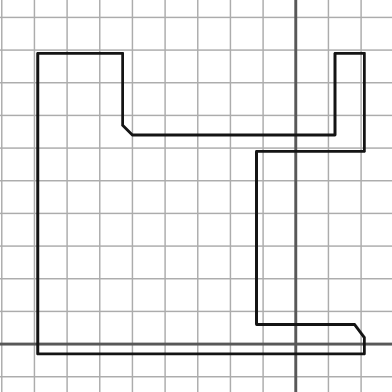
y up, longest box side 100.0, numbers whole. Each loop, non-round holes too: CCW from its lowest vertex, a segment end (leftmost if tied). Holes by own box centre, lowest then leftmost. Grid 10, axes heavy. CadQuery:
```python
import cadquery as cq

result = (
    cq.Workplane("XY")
    .moveTo(-79.0, -3.0)
    .lineTo(21.0, -3.0)
    .lineTo(21.0, 2.0)
    .lineTo(18.0, 6.0)
    .lineTo(-12.0, 6.0)
    .lineTo(-12.0, 59.0)
    .lineTo(21.0, 59.0)
    .lineTo(21.0, 89.0)
    .lineTo(12.0, 89.0)
    .lineTo(12.0, 64.0)
    .lineTo(-50.0, 64.0)
    .lineTo(-53.0, 67.0)
    .lineTo(-53.0, 89.0)
    .lineTo(-79.0, 89.0)
    .close()
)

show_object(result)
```